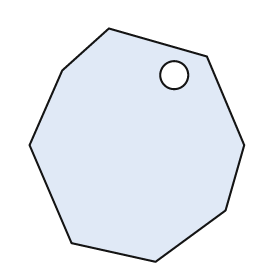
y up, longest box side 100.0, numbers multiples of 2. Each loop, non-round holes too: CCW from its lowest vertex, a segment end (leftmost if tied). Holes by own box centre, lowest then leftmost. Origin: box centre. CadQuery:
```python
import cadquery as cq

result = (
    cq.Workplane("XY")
    .moveTo(8.0, -50.0)
    .lineTo(38.0, -28.0)
    .lineTo(46.0, 0.0)
    .lineTo(30.0, 38.0)
    .lineTo(-12.0, 50.0)
    .lineTo(-32.0, 32.0)
    .lineTo(-46.0, 0.0)
    .lineTo(-28.0, -42.0)
    .close()
    .moveTo(16.0, 30.0)
    .circle(6.0)
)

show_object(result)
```